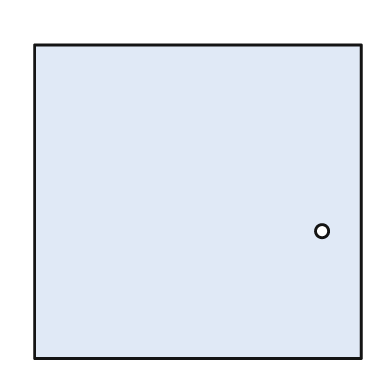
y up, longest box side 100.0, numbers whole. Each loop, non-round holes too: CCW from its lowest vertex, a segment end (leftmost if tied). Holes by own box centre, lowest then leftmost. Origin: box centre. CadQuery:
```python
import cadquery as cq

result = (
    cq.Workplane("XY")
    .moveTo(-50.0, -48.0)
    .lineTo(50.0, -48.0)
    .lineTo(50.0, 48.0)
    .lineTo(-50.0, 48.0)
    .close()
    .moveTo(38.0, -9.0)
    .circle(2.0)
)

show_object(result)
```